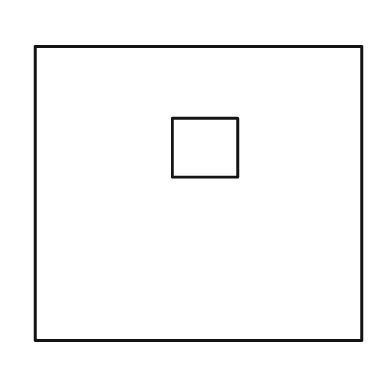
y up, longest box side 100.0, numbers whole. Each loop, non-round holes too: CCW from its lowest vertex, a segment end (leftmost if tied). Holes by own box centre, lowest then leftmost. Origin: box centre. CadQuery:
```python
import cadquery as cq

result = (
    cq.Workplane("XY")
    .moveTo(-50.0, -45.0)
    .lineTo(50.0, -45.0)
    .lineTo(50.0, 45.0)
    .lineTo(-50.0, 45.0)
    .close()
    .moveTo(-8.0, 5.0)
    .lineTo(12.0, 5.0)
    .lineTo(12.0, 23.0)
    .lineTo(-8.0, 23.0)
    .close()
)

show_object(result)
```